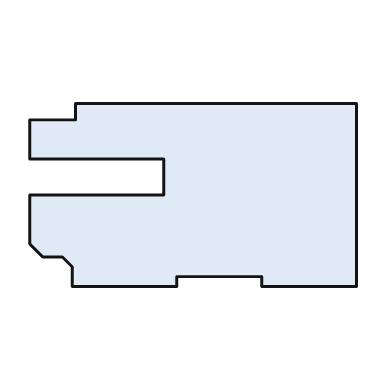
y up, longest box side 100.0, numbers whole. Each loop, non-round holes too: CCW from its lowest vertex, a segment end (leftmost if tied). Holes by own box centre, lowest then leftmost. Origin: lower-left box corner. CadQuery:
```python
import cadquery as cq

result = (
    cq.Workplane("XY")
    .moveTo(13.0, 0.0)
    .lineTo(45.0, 0.0)
    .lineTo(45.0, 3.0)
    .lineTo(71.0, 3.0)
    .lineTo(71.0, 0.0)
    .lineTo(100.0, 0.0)
    .lineTo(100.0, 56.0)
    .lineTo(14.0, 56.0)
    .lineTo(14.0, 51.0)
    .lineTo(0.0, 51.0)
    .lineTo(0.0, 39.0)
    .lineTo(41.0, 39.0)
    .lineTo(41.0, 28.0)
    .lineTo(0.0, 28.0)
    .lineTo(0.0, 13.0)
    .lineTo(4.0, 9.0)
    .lineTo(10.0, 9.0)
    .lineTo(13.0, 6.0)
    .close()
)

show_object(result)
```